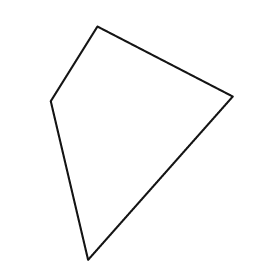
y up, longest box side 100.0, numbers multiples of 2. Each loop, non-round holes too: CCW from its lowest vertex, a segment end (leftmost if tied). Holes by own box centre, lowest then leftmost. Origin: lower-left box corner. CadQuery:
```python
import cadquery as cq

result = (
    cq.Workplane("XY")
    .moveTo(16.0, 0.0)
    .lineTo(78.0, 70.0)
    .lineTo(20.0, 100.0)
    .lineTo(0.0, 68.0)
    .close()
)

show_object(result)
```